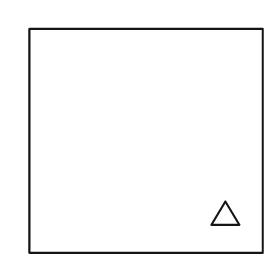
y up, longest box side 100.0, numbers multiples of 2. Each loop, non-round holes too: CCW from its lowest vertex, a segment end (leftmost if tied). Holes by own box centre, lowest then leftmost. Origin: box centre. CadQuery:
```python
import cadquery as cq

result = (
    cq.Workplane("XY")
    .moveTo(-50.0, -48.0)
    .lineTo(50.0, -48.0)
    .lineTo(50.0, 48.0)
    .lineTo(-50.0, 48.0)
    .close()
    .moveTo(28.0, -36.0)
    .lineTo(40.0, -36.0)
    .lineTo(34.0, -26.0)
    .close()
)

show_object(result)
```